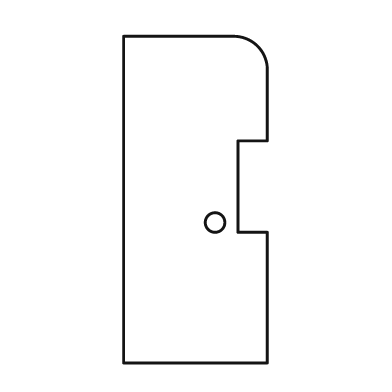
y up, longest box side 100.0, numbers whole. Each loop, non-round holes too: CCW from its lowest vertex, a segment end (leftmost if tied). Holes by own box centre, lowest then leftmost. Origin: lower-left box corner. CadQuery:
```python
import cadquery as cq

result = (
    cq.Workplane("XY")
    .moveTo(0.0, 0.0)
    .lineTo(44.0, 0.0)
    .lineTo(44.0, 40.0)
    .lineTo(35.0, 40.0)
    .lineTo(35.0, 68.0)
    .lineTo(44.0, 68.0)
    .lineTo(44.0, 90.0)
    .threePointArc((41.0, 97.0), (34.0, 100.0))
    .lineTo(0.0, 100.0)
    .close()
    .moveTo(28.0, 43.0)
    .circle(3.0)
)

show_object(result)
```